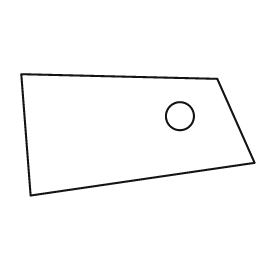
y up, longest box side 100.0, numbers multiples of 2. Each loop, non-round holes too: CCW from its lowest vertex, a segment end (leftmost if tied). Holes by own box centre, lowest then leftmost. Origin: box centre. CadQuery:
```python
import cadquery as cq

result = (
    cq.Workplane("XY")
    .moveTo(-46.0, -26.0)
    .lineTo(50.0, -12.0)
    .lineTo(34.0, 24.0)
    .lineTo(-50.0, 26.0)
    .close()
    .moveTo(18.0, 8.0)
    .circle(6.0)
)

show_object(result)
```